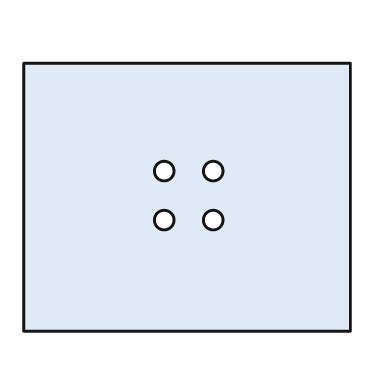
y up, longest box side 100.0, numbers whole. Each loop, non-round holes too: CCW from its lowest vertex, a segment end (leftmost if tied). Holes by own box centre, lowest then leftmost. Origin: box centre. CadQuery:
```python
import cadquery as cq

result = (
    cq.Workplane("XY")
    .moveTo(-50.0, -41.0)
    .lineTo(50.0, -41.0)
    .lineTo(50.0, 41.0)
    .lineTo(-50.0, 41.0)
    .close()
    .moveTo(-7.0, -7.0)
    .circle(3.0)
    .moveTo(8.0, -7.0)
    .circle(3.0)
    .moveTo(-7.0, 8.0)
    .circle(3.0)
    .moveTo(8.0, 8.0)
    .circle(3.0)
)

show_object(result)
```